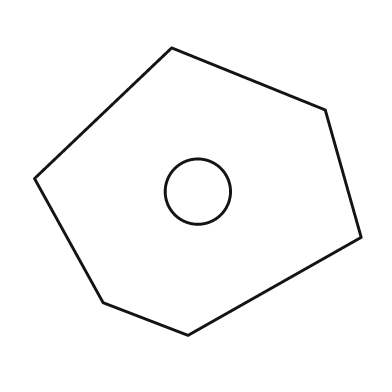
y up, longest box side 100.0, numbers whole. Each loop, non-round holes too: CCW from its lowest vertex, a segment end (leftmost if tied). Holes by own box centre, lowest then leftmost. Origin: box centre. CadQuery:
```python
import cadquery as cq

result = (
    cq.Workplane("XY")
    .moveTo(-3.0, -44.0)
    .lineTo(50.0, -14.0)
    .lineTo(39.0, 25.0)
    .lineTo(-8.0, 44.0)
    .lineTo(-50.0, 4.0)
    .lineTo(-29.0, -34.0)
    .close()
    .moveTo(0.0, 0.0)
    .circle(10.0)
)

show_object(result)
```